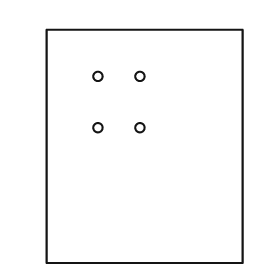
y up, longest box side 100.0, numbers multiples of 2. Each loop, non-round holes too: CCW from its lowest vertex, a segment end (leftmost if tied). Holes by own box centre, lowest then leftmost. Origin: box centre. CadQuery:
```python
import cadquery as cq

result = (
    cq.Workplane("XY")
    .moveTo(-42.0, -50.0)
    .lineTo(42.0, -50.0)
    .lineTo(42.0, 50.0)
    .lineTo(-42.0, 50.0)
    .close()
    .moveTo(-20.0, 8.0)
    .circle(2.0)
    .moveTo(-2.0, 8.0)
    .circle(2.0)
    .moveTo(-20.0, 30.0)
    .circle(2.0)
    .moveTo(-2.0, 30.0)
    .circle(2.0)
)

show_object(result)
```